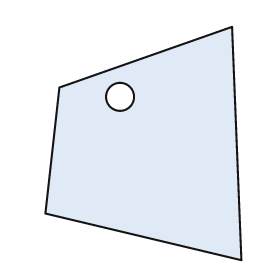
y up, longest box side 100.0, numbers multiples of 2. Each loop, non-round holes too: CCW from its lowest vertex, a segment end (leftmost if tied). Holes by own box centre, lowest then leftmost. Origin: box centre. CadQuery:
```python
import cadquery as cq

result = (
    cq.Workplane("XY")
    .moveTo(42.0, -50.0)
    .lineTo(38.0, 50.0)
    .lineTo(-36.0, 24.0)
    .lineTo(-42.0, -30.0)
    .close()
    .moveTo(-10.0, 20.0)
    .circle(6.0)
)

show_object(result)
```